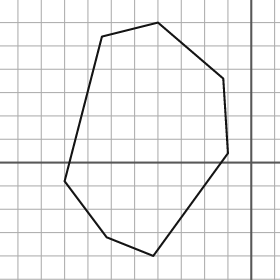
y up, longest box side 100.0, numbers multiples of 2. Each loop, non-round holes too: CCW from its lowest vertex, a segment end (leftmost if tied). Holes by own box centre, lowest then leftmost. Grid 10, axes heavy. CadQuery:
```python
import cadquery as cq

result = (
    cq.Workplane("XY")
    .moveTo(-42.0, -40.0)
    .lineTo(-10.0, 4.0)
    .lineTo(-12.0, 36.0)
    .lineTo(-40.0, 60.0)
    .lineTo(-64.0, 54.0)
    .lineTo(-80.0, -8.0)
    .lineTo(-62.0, -32.0)
    .close()
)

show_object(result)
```